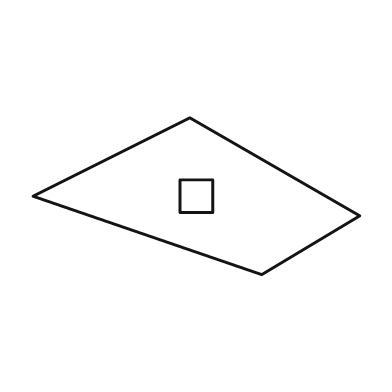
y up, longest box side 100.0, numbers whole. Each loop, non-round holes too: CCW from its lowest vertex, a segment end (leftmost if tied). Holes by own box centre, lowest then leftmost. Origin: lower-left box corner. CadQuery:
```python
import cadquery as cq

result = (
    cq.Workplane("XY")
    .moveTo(70.0, 0.0)
    .lineTo(100.0, 18.0)
    .lineTo(48.0, 48.0)
    .lineTo(0.0, 24.0)
    .close()
    .moveTo(45.0, 19.0)
    .lineTo(55.0, 19.0)
    .lineTo(55.0, 29.0)
    .lineTo(45.0, 29.0)
    .close()
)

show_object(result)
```